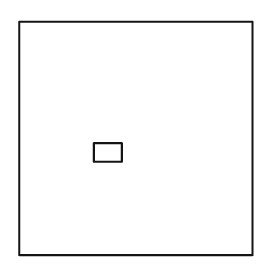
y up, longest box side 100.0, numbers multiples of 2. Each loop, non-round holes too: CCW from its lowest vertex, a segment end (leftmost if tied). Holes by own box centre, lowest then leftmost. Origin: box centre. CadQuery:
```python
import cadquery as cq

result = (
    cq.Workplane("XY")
    .moveTo(-50.0, -50.0)
    .lineTo(50.0, -50.0)
    .lineTo(50.0, 50.0)
    .lineTo(-50.0, 50.0)
    .close()
    .moveTo(-18.0, -10.0)
    .lineTo(-6.0, -10.0)
    .lineTo(-6.0, -2.0)
    .lineTo(-18.0, -2.0)
    .close()
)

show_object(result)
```